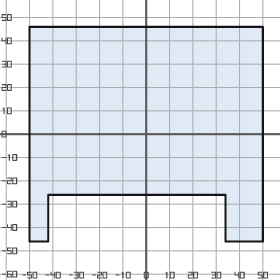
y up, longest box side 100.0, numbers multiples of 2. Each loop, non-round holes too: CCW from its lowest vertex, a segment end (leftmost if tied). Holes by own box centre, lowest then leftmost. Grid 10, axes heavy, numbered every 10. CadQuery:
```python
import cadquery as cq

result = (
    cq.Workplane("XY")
    .moveTo(-50.0, -46.0)
    .lineTo(-42.0, -46.0)
    .lineTo(-42.0, -26.0)
    .lineTo(34.0, -26.0)
    .lineTo(34.0, -46.0)
    .lineTo(50.0, -46.0)
    .lineTo(50.0, 46.0)
    .lineTo(-50.0, 46.0)
    .close()
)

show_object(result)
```